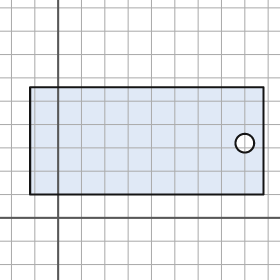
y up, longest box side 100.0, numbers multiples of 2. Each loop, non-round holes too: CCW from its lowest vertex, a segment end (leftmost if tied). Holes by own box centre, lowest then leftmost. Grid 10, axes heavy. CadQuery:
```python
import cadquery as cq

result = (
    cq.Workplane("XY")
    .moveTo(-12.0, 10.0)
    .lineTo(88.0, 10.0)
    .lineTo(88.0, 56.0)
    .lineTo(-12.0, 56.0)
    .close()
    .moveTo(80.0, 32.0)
    .circle(4.0)
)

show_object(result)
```